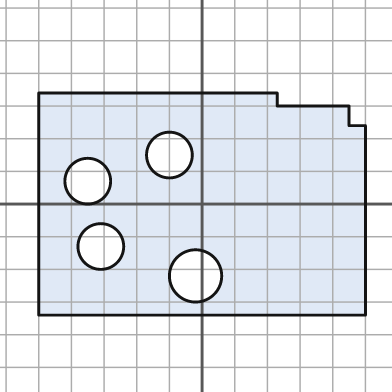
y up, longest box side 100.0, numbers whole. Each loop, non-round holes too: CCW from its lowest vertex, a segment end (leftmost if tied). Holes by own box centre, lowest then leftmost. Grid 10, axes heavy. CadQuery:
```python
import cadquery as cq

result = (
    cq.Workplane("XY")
    .moveTo(-50.0, -34.0)
    .lineTo(50.0, -34.0)
    .lineTo(50.0, 24.0)
    .lineTo(45.0, 24.0)
    .lineTo(45.0, 30.0)
    .lineTo(23.0, 30.0)
    .lineTo(23.0, 34.0)
    .lineTo(-50.0, 34.0)
    .close()
    .moveTo(-2.0, -22.0)
    .circle(8.0)
    .moveTo(-31.0, -13.0)
    .circle(7.0)
    .moveTo(-35.0, 7.0)
    .circle(7.0)
    .moveTo(-10.0, 15.0)
    .circle(7.0)
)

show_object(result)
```